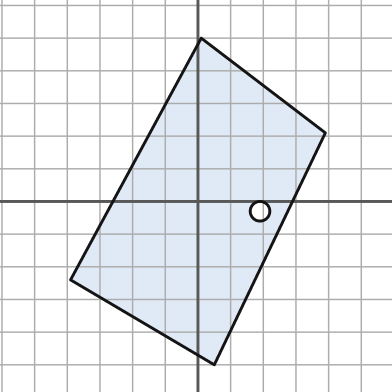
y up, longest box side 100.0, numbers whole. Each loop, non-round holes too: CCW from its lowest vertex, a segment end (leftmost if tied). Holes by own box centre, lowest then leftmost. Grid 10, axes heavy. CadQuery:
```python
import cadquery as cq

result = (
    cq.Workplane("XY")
    .moveTo(5.0, -50.0)
    .lineTo(39.0, 21.0)
    .lineTo(1.0, 50.0)
    .lineTo(-39.0, -24.0)
    .close()
    .moveTo(19.0, -3.0)
    .circle(3.0)
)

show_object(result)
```